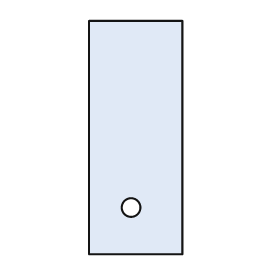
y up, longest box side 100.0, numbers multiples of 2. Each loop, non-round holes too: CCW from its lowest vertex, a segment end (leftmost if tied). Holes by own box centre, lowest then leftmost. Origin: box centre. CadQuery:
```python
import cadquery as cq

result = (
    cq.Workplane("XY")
    .moveTo(-20.0, -50.0)
    .lineTo(20.0, -50.0)
    .lineTo(20.0, 50.0)
    .lineTo(-20.0, 50.0)
    .close()
    .moveTo(-2.0, -30.0)
    .circle(4.0)
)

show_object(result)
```